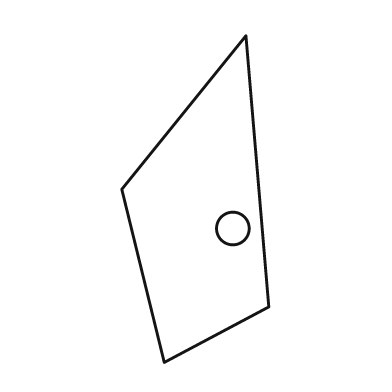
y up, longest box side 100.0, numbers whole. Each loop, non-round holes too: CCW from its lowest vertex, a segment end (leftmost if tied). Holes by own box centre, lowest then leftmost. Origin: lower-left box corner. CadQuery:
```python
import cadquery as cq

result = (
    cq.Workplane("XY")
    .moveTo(13.0, 0.0)
    .lineTo(45.0, 17.0)
    .lineTo(38.0, 100.0)
    .lineTo(0.0, 53.0)
    .close()
    .moveTo(34.0, 41.0)
    .circle(5.0)
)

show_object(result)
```